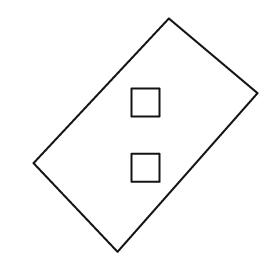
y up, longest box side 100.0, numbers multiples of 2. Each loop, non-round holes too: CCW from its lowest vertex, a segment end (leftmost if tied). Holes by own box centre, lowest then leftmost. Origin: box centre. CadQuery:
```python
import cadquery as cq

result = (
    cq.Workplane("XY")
    .moveTo(-12.0, -50.0)
    .lineTo(48.0, 18.0)
    .lineTo(10.0, 50.0)
    .lineTo(-48.0, -12.0)
    .close()
    .moveTo(-6.0, -20.0)
    .lineTo(6.0, -20.0)
    .lineTo(6.0, -8.0)
    .lineTo(-6.0, -8.0)
    .close()
    .moveTo(-6.0, 8.0)
    .lineTo(6.0, 8.0)
    .lineTo(6.0, 20.0)
    .lineTo(-6.0, 20.0)
    .close()
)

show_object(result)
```